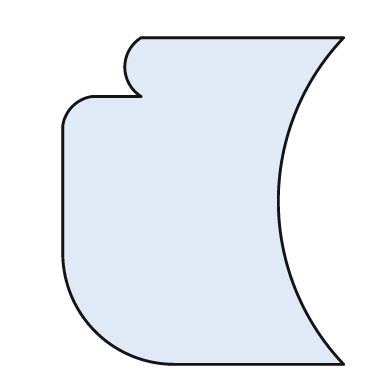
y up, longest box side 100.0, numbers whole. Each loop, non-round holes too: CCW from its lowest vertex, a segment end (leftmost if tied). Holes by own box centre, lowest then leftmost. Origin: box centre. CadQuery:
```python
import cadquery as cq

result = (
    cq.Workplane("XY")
    .moveTo(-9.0, -50.0)
    .lineTo(43.0, -50.0)
    .threePointArc((23.0, 0.0), (43.0, 50.0))
    .lineTo(-19.0, 50.0)
    .threePointArc((-24.0, 41.0), (-19.0, 32.0))
    .lineTo(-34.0, 32.0)
    .threePointArc((-40.0, 29.0), (-43.0, 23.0))
    .lineTo(-43.0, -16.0)
    .threePointArc((-33.0, -40.0), (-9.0, -50.0))
    .close()
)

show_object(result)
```